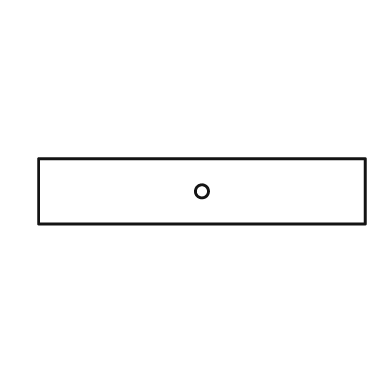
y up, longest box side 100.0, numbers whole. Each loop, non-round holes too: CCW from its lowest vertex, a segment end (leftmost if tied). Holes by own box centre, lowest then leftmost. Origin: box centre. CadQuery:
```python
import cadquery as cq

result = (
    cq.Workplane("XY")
    .moveTo(-50.0, -10.0)
    .lineTo(50.0, -10.0)
    .lineTo(50.0, 10.0)
    .lineTo(-50.0, 10.0)
    .close()
    .moveTo(0.0, 0.0)
    .circle(2.0)
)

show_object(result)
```